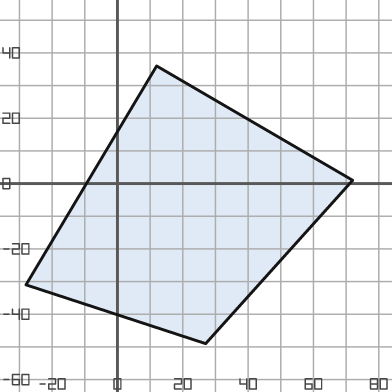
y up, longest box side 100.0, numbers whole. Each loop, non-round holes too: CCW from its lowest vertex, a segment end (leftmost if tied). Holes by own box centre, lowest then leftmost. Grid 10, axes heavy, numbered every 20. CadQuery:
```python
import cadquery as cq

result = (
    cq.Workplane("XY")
    .moveTo(27.0, -49.0)
    .lineTo(72.0, 1.0)
    .lineTo(12.0, 36.0)
    .lineTo(-28.0, -31.0)
    .close()
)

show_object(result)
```